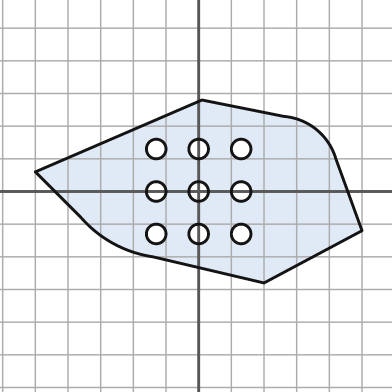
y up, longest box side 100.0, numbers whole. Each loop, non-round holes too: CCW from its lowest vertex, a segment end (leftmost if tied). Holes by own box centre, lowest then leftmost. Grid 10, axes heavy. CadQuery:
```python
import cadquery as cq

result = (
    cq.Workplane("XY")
    .moveTo(20.0, -28.0)
    .lineTo(50.0, -12.0)
    .lineTo(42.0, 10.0)
    .threePointArc((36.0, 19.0), (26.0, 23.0))
    .lineTo(1.0, 28.0)
    .lineTo(-50.0, 6.0)
    .lineTo(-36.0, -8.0)
    .threePointArc((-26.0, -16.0), (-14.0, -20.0))
    .close()
    .moveTo(-13.0, -13.0)
    .circle(3.0)
    .moveTo(0.0, -13.0)
    .circle(3.0)
    .moveTo(13.0, -13.0)
    .circle(3.0)
    .moveTo(-13.0, 0.0)
    .circle(3.0)
    .moveTo(0.0, 0.0)
    .circle(3.0)
    .moveTo(13.0, 0.0)
    .circle(3.0)
    .moveTo(-13.0, 13.0)
    .circle(3.0)
    .moveTo(0.0, 13.0)
    .circle(3.0)
    .moveTo(13.0, 13.0)
    .circle(3.0)
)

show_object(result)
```